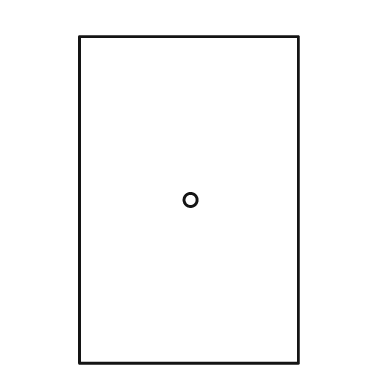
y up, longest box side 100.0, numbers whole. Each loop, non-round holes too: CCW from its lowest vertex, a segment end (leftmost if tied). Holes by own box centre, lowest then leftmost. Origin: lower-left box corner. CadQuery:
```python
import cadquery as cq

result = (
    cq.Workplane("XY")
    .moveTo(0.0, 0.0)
    .lineTo(67.0, 0.0)
    .lineTo(67.0, 100.0)
    .lineTo(0.0, 100.0)
    .close()
    .moveTo(34.0, 50.0)
    .circle(2.0)
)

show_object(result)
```